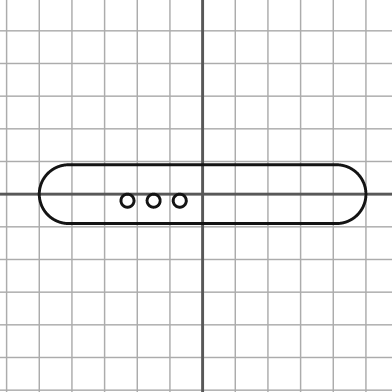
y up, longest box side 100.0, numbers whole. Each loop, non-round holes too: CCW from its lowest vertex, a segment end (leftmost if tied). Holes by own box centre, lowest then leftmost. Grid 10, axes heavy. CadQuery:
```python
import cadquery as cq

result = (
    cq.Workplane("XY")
    .moveTo(-41.0, -9.0)
    .lineTo(41.0, -9.0)
    .threePointArc((50.0, 0.0), (41.0, 9.0))
    .lineTo(-41.0, 9.0)
    .threePointArc((-50.0, 0.0), (-41.0, -9.0))
    .close()
    .moveTo(-23.0, -2.0)
    .circle(2.0)
    .moveTo(-15.0, -2.0)
    .circle(2.0)
    .moveTo(-7.0, -2.0)
    .circle(2.0)
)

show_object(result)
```